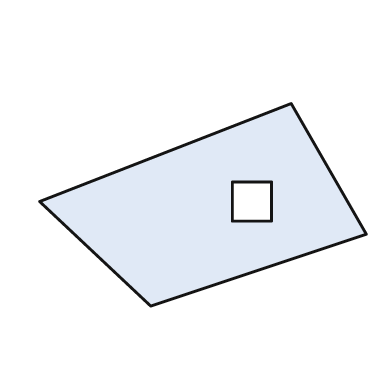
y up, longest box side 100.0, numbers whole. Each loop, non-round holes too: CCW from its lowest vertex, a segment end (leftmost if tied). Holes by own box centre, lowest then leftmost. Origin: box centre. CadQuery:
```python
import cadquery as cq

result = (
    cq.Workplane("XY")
    .moveTo(-16.0, -31.0)
    .lineTo(50.0, -9.0)
    .lineTo(27.0, 31.0)
    .lineTo(-50.0, 1.0)
    .close()
    .moveTo(9.0, -5.0)
    .lineTo(21.0, -5.0)
    .lineTo(21.0, 7.0)
    .lineTo(9.0, 7.0)
    .close()
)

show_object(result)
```